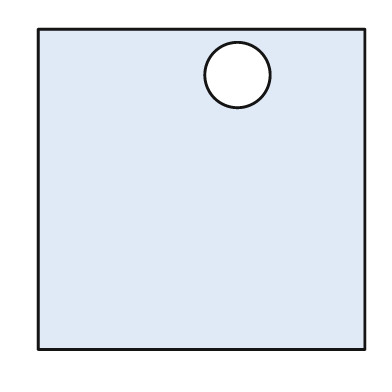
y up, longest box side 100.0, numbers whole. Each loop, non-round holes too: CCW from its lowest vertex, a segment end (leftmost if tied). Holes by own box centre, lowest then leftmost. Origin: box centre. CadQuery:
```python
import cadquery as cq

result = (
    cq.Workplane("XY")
    .moveTo(-50.0, -49.0)
    .lineTo(50.0, -49.0)
    .lineTo(50.0, 49.0)
    .lineTo(-50.0, 49.0)
    .close()
    .moveTo(11.0, 35.0)
    .circle(10.0)
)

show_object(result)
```